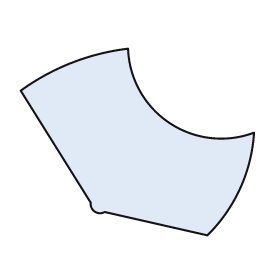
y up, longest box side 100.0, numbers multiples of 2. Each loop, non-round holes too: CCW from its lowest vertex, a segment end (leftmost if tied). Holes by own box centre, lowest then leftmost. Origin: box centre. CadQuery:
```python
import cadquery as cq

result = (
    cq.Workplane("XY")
    .moveTo(30.0, -40.0)
    .threePointArc((44.0, -20.0), (50.0, 4.0))
    .threePointArc((14.0, 8.0), (-4.0, 40.0))
    .threePointArc((-28.0, 34.0), (-50.0, 22.0))
    .lineTo(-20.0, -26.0)
    .threePointArc((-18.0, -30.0), (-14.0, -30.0))
    .close()
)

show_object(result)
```